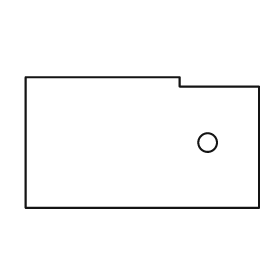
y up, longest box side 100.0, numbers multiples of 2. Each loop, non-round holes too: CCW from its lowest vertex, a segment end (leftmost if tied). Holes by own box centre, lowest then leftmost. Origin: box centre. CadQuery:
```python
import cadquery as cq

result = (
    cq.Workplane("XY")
    .moveTo(-50.0, -28.0)
    .lineTo(50.0, -28.0)
    .lineTo(50.0, 24.0)
    .lineTo(16.0, 24.0)
    .lineTo(16.0, 28.0)
    .lineTo(-50.0, 28.0)
    .close()
    .moveTo(28.0, 0.0)
    .circle(4.0)
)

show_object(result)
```